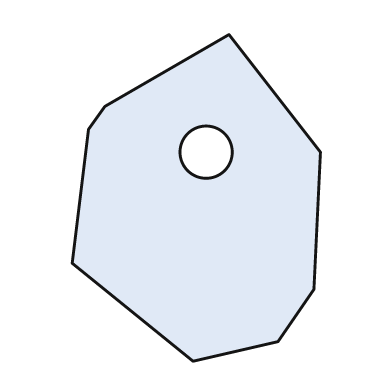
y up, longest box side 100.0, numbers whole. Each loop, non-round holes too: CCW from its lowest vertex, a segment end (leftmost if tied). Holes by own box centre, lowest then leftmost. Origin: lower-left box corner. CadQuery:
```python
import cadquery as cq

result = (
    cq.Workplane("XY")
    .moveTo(37.0, 0.0)
    .lineTo(63.0, 6.0)
    .lineTo(74.0, 22.0)
    .lineTo(76.0, 64.0)
    .lineTo(48.0, 100.0)
    .lineTo(10.0, 78.0)
    .lineTo(5.0, 71.0)
    .lineTo(0.0, 30.0)
    .close()
    .moveTo(41.0, 64.0)
    .circle(8.0)
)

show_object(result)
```